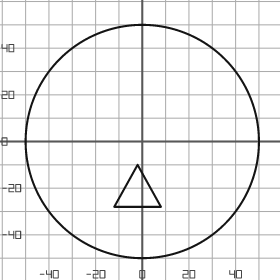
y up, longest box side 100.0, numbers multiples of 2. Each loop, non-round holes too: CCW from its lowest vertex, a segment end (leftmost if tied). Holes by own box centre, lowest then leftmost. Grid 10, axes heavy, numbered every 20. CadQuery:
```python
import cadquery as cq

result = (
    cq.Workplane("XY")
    .moveTo(0.0, 0.0)
    .circle(50.0)
    .moveTo(-12.0, -28.0)
    .lineTo(8.0, -28.0)
    .lineTo(-2.0, -10.0)
    .close()
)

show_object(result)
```